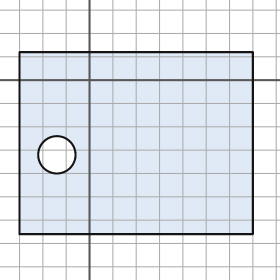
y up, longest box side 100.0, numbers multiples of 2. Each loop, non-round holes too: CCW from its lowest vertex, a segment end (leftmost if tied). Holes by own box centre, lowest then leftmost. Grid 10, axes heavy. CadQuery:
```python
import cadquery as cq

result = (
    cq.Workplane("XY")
    .moveTo(-30.0, -66.0)
    .lineTo(70.0, -66.0)
    .lineTo(70.0, 12.0)
    .lineTo(-30.0, 12.0)
    .close()
    .moveTo(-14.0, -32.0)
    .circle(8.0)
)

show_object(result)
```